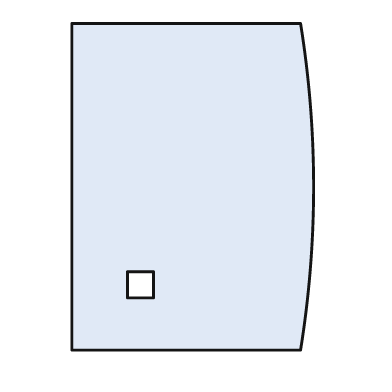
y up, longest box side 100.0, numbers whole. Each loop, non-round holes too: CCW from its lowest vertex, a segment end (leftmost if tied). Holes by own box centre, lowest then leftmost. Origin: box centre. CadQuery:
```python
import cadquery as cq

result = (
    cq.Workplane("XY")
    .moveTo(-37.0, -50.0)
    .lineTo(33.0, -50.0)
    .threePointArc((37.0, 0.0), (33.0, 50.0))
    .lineTo(-37.0, 50.0)
    .close()
    .moveTo(-20.0, -34.0)
    .lineTo(-12.0, -34.0)
    .lineTo(-12.0, -26.0)
    .lineTo(-20.0, -26.0)
    .close()
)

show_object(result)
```